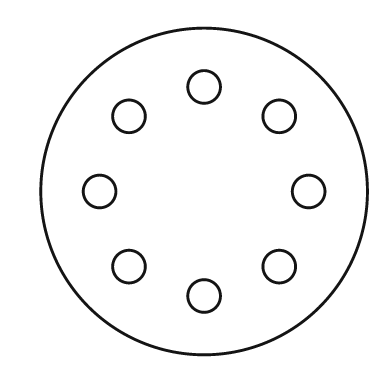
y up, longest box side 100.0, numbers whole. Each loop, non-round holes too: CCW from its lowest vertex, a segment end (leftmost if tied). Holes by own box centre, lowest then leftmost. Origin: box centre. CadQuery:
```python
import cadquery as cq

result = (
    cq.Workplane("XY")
    .moveTo(0.0, 0.0)
    .circle(50.0)
    .moveTo(0.0, -32.0)
    .circle(5.0)
    .moveTo(-23.0, -23.0)
    .circle(5.0)
    .moveTo(23.0, -23.0)
    .circle(5.0)
    .moveTo(-32.0, 0.0)
    .circle(5.0)
    .moveTo(32.0, 0.0)
    .circle(5.0)
    .moveTo(-23.0, 23.0)
    .circle(5.0)
    .moveTo(23.0, 23.0)
    .circle(5.0)
    .moveTo(0.0, 32.0)
    .circle(5.0)
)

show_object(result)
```